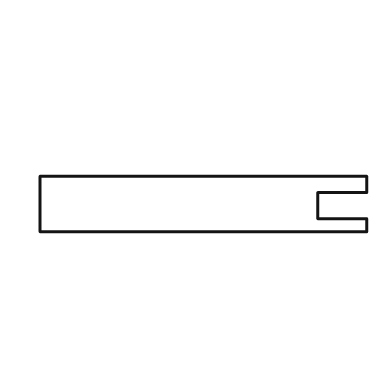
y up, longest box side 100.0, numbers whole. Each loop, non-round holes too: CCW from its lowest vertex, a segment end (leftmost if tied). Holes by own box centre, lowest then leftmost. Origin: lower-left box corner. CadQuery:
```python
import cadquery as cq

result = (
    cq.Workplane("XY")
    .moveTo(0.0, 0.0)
    .lineTo(100.0, 0.0)
    .lineTo(100.0, 4.0)
    .lineTo(85.0, 4.0)
    .lineTo(85.0, 12.0)
    .lineTo(100.0, 12.0)
    .lineTo(100.0, 17.0)
    .lineTo(0.0, 17.0)
    .close()
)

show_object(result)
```